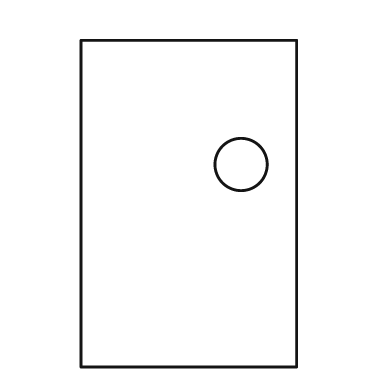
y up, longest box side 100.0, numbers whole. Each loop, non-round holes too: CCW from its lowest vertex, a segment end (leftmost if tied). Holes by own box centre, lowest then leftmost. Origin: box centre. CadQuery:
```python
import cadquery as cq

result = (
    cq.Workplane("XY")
    .moveTo(-33.0, -50.0)
    .lineTo(33.0, -50.0)
    .lineTo(33.0, 50.0)
    .lineTo(-33.0, 50.0)
    .close()
    .moveTo(16.0, 12.0)
    .circle(8.0)
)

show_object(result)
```